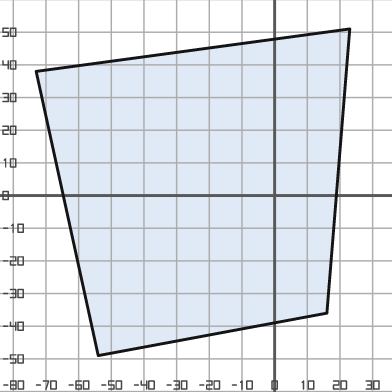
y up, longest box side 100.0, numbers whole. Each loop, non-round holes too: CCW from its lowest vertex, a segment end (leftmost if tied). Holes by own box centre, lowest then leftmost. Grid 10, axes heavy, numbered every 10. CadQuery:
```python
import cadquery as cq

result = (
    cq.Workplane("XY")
    .moveTo(-54.0, -49.0)
    .lineTo(16.0, -36.0)
    .lineTo(23.0, 51.0)
    .lineTo(-73.0, 38.0)
    .close()
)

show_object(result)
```